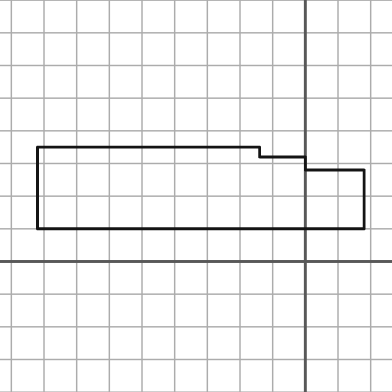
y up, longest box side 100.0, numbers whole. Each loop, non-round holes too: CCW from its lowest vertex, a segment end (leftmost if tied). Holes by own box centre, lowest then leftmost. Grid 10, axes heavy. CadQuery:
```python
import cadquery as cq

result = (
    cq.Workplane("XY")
    .moveTo(-82.0, 10.0)
    .lineTo(18.0, 10.0)
    .lineTo(18.0, 28.0)
    .lineTo(0.0, 28.0)
    .lineTo(0.0, 32.0)
    .lineTo(-14.0, 32.0)
    .lineTo(-14.0, 35.0)
    .lineTo(-82.0, 35.0)
    .close()
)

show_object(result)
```